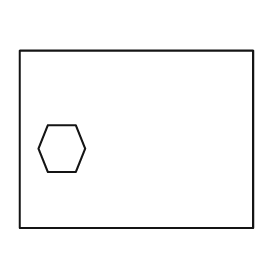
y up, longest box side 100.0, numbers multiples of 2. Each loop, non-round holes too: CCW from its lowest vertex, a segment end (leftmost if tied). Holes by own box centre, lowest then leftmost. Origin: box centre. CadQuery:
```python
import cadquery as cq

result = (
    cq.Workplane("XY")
    .moveTo(-50.0, -38.0)
    .lineTo(50.0, -38.0)
    .lineTo(50.0, 38.0)
    .lineTo(-50.0, 38.0)
    .close()
    .moveTo(-38.0, -14.0)
    .lineTo(-26.0, -14.0)
    .lineTo(-22.0, -4.0)
    .lineTo(-26.0, 6.0)
    .lineTo(-38.0, 6.0)
    .lineTo(-42.0, -4.0)
    .close()
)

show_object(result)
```